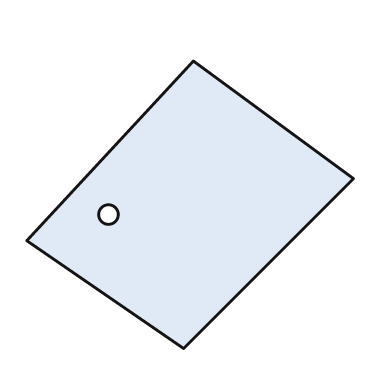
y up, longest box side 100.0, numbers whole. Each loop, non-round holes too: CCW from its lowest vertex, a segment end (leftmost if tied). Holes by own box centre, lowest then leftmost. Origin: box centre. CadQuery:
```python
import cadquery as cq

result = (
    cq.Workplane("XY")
    .moveTo(-2.0, -44.0)
    .lineTo(50.0, 8.0)
    .lineTo(1.0, 44.0)
    .lineTo(-50.0, -11.0)
    .close()
    .moveTo(-25.0, -3.0)
    .circle(3.0)
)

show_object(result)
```